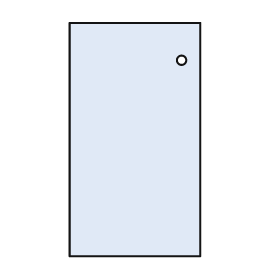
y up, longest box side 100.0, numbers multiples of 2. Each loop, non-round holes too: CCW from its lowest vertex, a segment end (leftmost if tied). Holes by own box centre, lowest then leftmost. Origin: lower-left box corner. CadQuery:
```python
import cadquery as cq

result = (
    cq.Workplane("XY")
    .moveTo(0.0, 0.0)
    .lineTo(56.0, 0.0)
    .lineTo(56.0, 100.0)
    .lineTo(0.0, 100.0)
    .close()
    .moveTo(48.0, 84.0)
    .circle(2.0)
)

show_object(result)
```